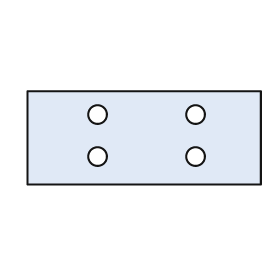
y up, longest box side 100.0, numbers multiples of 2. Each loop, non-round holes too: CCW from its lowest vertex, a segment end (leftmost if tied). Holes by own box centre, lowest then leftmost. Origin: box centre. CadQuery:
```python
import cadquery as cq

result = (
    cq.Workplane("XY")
    .moveTo(-50.0, -20.0)
    .lineTo(50.0, -20.0)
    .lineTo(50.0, 20.0)
    .lineTo(-50.0, 20.0)
    .close()
    .moveTo(-20.0, -8.0)
    .circle(4.0)
    .moveTo(22.0, -8.0)
    .circle(4.0)
    .moveTo(-20.0, 10.0)
    .circle(4.0)
    .moveTo(22.0, 10.0)
    .circle(4.0)
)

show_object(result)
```